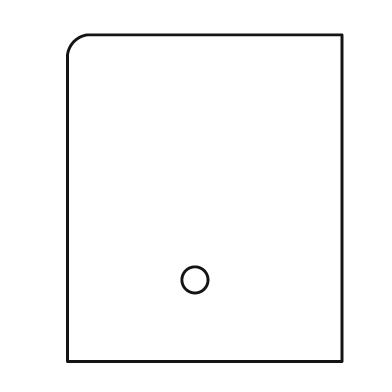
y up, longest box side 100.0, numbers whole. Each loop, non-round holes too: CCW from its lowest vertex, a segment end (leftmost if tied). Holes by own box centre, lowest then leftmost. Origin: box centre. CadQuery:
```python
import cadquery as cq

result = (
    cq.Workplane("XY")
    .moveTo(-42.0, -50.0)
    .lineTo(42.0, -50.0)
    .lineTo(42.0, 50.0)
    .lineTo(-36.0, 50.0)
    .threePointArc((-40.0, 48.0), (-42.0, 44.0))
    .close()
    .moveTo(-3.0, -25.0)
    .circle(4.0)
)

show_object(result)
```